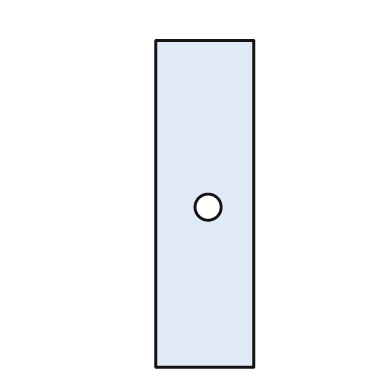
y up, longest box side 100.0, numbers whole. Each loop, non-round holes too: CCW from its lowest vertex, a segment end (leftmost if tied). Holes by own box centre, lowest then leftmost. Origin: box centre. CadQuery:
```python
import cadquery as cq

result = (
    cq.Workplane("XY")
    .moveTo(-15.0, -50.0)
    .lineTo(15.0, -50.0)
    .lineTo(15.0, 50.0)
    .lineTo(-15.0, 50.0)
    .close()
    .moveTo(1.0, -1.0)
    .circle(4.0)
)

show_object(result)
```